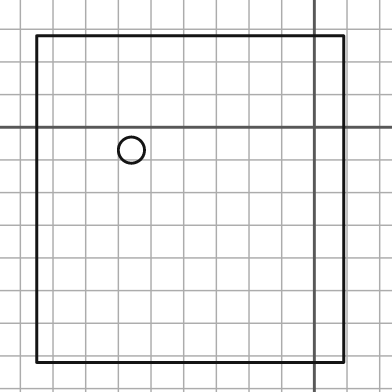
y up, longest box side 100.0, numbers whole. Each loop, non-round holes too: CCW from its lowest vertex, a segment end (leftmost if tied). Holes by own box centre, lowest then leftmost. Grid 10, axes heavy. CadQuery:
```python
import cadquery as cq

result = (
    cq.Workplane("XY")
    .moveTo(-85.0, -72.0)
    .lineTo(9.0, -72.0)
    .lineTo(9.0, 28.0)
    .lineTo(-85.0, 28.0)
    .close()
    .moveTo(-56.0, -7.0)
    .circle(4.0)
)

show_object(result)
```